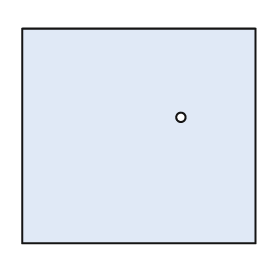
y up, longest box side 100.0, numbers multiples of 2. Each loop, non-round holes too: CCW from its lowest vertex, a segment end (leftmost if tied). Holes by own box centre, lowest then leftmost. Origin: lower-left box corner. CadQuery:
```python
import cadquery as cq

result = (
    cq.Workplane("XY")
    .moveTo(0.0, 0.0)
    .lineTo(100.0, 0.0)
    .lineTo(100.0, 92.0)
    .lineTo(0.0, 92.0)
    .close()
    .moveTo(68.0, 54.0)
    .circle(2.0)
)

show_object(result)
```